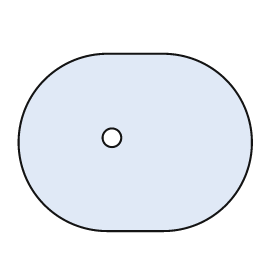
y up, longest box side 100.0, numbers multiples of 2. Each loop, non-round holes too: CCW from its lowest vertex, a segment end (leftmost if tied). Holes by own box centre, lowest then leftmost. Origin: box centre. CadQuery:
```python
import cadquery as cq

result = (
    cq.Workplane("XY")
    .moveTo(-12.0, -38.0)
    .lineTo(12.0, -38.0)
    .threePointArc((50.0, 0.0), (12.0, 38.0))
    .lineTo(-12.0, 38.0)
    .threePointArc((-50.0, 0.0), (-12.0, -38.0))
    .close()
    .moveTo(-10.0, 2.0)
    .circle(4.0)
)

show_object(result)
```